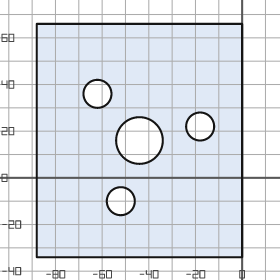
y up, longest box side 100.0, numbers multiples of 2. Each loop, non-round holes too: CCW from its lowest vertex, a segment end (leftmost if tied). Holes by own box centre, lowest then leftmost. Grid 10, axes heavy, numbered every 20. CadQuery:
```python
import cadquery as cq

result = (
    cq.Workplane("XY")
    .moveTo(-88.0, -34.0)
    .lineTo(0.0, -34.0)
    .lineTo(0.0, 66.0)
    .lineTo(-88.0, 66.0)
    .close()
    .moveTo(-52.0, -10.0)
    .circle(6.0)
    .moveTo(-44.0, 16.0)
    .circle(10.0)
    .moveTo(-18.0, 22.0)
    .circle(6.0)
    .moveTo(-62.0, 36.0)
    .circle(6.0)
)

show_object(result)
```